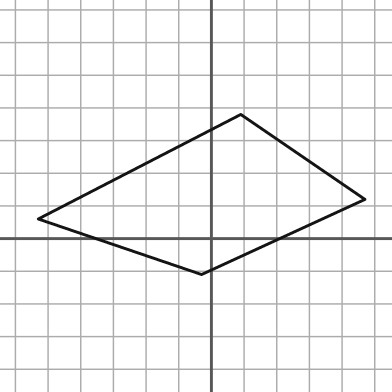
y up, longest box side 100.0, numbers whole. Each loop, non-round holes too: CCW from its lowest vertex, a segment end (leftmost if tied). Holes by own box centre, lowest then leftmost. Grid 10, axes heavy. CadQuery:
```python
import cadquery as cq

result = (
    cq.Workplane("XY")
    .moveTo(-3.0, -11.0)
    .lineTo(47.0, 12.0)
    .lineTo(9.0, 38.0)
    .lineTo(-53.0, 6.0)
    .close()
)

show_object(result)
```